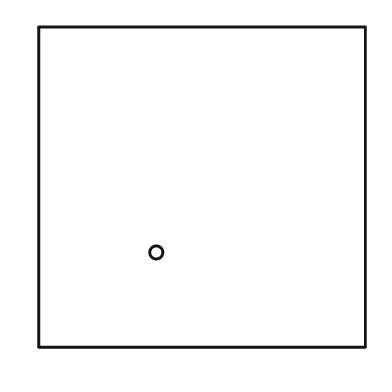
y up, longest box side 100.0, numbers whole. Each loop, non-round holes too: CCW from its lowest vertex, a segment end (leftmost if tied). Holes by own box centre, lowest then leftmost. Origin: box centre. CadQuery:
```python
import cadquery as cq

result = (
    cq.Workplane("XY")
    .moveTo(-50.0, -49.0)
    .lineTo(50.0, -49.0)
    .lineTo(50.0, 49.0)
    .lineTo(-50.0, 49.0)
    .close()
    .moveTo(-14.0, -20.0)
    .circle(2.0)
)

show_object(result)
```